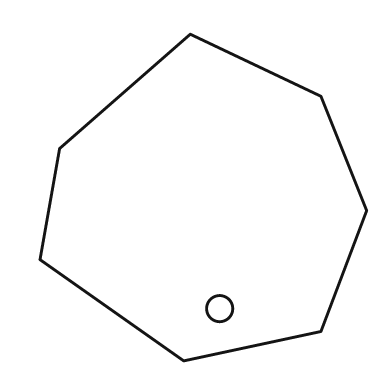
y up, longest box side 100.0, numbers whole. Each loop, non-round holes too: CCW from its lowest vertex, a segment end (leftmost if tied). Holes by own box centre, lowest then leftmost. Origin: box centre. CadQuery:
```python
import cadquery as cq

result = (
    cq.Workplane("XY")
    .moveTo(-6.0, -50.0)
    .lineTo(36.0, -41.0)
    .lineTo(50.0, -4.0)
    .lineTo(36.0, 31.0)
    .lineTo(-4.0, 50.0)
    .lineTo(-44.0, 15.0)
    .lineTo(-50.0, -19.0)
    .close()
    .moveTo(5.0, -34.0)
    .circle(4.0)
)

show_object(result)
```